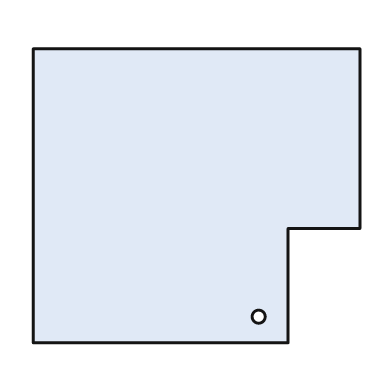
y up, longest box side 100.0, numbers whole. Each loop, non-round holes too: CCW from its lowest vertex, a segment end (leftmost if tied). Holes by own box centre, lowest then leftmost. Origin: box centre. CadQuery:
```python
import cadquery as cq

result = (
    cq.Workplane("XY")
    .moveTo(-50.0, -45.0)
    .lineTo(28.0, -45.0)
    .lineTo(28.0, -10.0)
    .lineTo(50.0, -10.0)
    .lineTo(50.0, 45.0)
    .lineTo(-50.0, 45.0)
    .close()
    .moveTo(19.0, -37.0)
    .circle(2.0)
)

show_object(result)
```